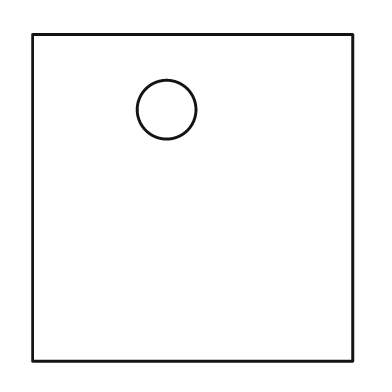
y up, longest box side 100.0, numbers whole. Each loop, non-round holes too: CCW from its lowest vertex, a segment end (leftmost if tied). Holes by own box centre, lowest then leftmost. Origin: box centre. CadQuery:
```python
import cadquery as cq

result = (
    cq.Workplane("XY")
    .moveTo(-49.0, -50.0)
    .lineTo(49.0, -50.0)
    .lineTo(49.0, 50.0)
    .lineTo(-49.0, 50.0)
    .close()
    .moveTo(-8.0, 27.0)
    .circle(9.0)
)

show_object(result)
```